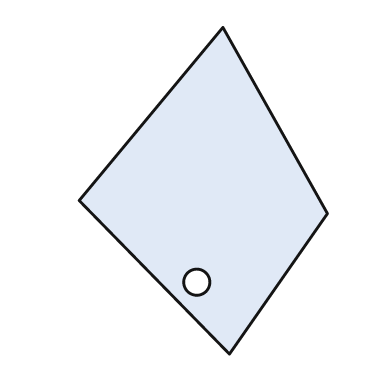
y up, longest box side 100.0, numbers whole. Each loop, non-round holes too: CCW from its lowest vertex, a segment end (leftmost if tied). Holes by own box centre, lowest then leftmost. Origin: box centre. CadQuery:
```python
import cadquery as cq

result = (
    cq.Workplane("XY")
    .moveTo(8.0, -50.0)
    .lineTo(38.0, -7.0)
    .lineTo(6.0, 50.0)
    .lineTo(-38.0, -3.0)
    .close()
    .moveTo(-2.0, -28.0)
    .circle(4.0)
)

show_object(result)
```